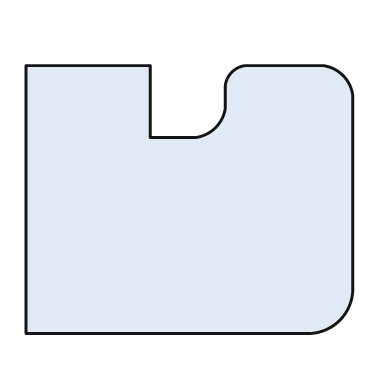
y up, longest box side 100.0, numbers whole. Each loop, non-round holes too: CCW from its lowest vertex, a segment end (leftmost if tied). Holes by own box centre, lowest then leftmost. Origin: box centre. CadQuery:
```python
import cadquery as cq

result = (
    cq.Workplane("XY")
    .moveTo(-50.0, -41.0)
    .lineTo(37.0, -41.0)
    .threePointArc((46.0, -37.0), (50.0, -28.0))
    .lineTo(50.0, 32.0)
    .threePointArc((47.0, 38.0), (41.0, 41.0))
    .lineTo(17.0, 41.0)
    .threePointArc((13.0, 39.0), (11.0, 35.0))
    .lineTo(11.0, 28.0)
    .threePointArc((8.0, 22.0), (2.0, 19.0))
    .lineTo(-12.0, 19.0)
    .lineTo(-12.0, 41.0)
    .lineTo(-50.0, 41.0)
    .close()
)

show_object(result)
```